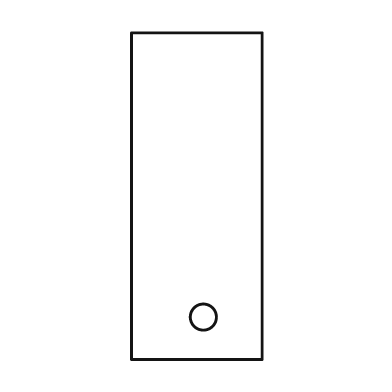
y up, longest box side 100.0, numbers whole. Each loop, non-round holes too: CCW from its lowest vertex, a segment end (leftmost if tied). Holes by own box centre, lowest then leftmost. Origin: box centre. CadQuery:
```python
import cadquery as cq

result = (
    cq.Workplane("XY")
    .moveTo(-20.0, -50.0)
    .lineTo(20.0, -50.0)
    .lineTo(20.0, 50.0)
    .lineTo(-20.0, 50.0)
    .close()
    .moveTo(2.0, -37.0)
    .circle(4.0)
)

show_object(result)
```